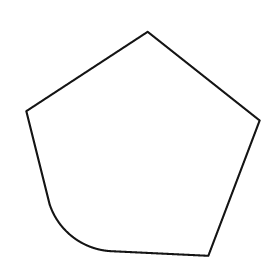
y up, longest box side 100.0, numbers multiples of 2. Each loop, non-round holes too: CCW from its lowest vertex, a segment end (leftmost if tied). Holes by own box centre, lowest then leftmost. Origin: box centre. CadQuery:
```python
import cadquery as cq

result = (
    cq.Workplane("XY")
    .moveTo(28.0, -48.0)
    .lineTo(50.0, 10.0)
    .lineTo(2.0, 48.0)
    .lineTo(-50.0, 14.0)
    .lineTo(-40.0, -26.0)
    .threePointArc((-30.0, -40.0), (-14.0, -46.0))
    .close()
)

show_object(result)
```